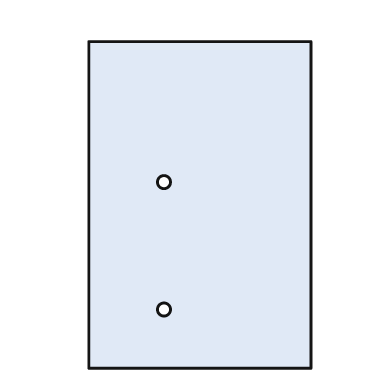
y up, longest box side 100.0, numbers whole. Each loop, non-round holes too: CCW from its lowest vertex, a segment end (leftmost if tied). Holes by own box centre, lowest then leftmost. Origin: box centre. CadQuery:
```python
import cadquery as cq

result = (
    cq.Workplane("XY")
    .moveTo(-34.0, -50.0)
    .lineTo(34.0, -50.0)
    .lineTo(34.0, 50.0)
    .lineTo(-34.0, 50.0)
    .close()
    .moveTo(-11.0, -32.0)
    .circle(2.0)
    .moveTo(-11.0, 7.0)
    .circle(2.0)
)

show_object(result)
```